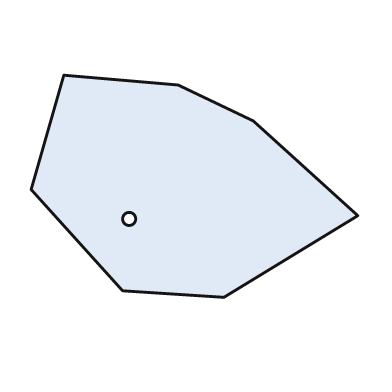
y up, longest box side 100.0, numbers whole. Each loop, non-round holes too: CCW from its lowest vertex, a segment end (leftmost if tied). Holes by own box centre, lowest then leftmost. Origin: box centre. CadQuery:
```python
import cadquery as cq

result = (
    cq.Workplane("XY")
    .moveTo(9.0, -34.0)
    .lineTo(50.0, -9.0)
    .lineTo(18.0, 20.0)
    .lineTo(-5.0, 31.0)
    .lineTo(-40.0, 34.0)
    .lineTo(-50.0, -1.0)
    .lineTo(-22.0, -32.0)
    .close()
    .moveTo(-20.0, -10.0)
    .circle(2.0)
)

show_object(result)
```